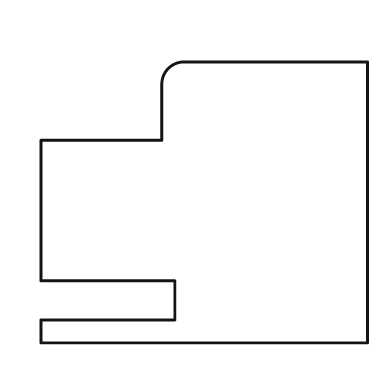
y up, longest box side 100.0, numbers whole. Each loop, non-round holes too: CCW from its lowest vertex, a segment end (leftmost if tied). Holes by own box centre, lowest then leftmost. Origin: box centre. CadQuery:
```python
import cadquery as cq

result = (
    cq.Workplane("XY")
    .moveTo(-50.0, -43.0)
    .lineTo(50.0, -43.0)
    .lineTo(50.0, 43.0)
    .lineTo(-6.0, 43.0)
    .threePointArc((-11.0, 41.0), (-13.0, 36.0))
    .lineTo(-13.0, 19.0)
    .lineTo(-50.0, 19.0)
    .lineTo(-50.0, -24.0)
    .lineTo(-9.0, -24.0)
    .lineTo(-9.0, -36.0)
    .lineTo(-50.0, -36.0)
    .close()
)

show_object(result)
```